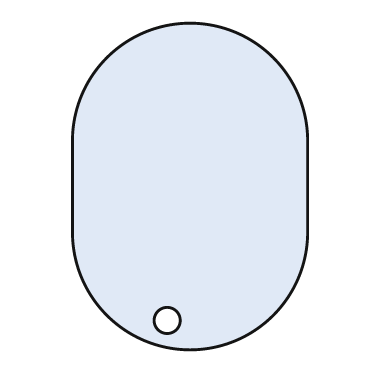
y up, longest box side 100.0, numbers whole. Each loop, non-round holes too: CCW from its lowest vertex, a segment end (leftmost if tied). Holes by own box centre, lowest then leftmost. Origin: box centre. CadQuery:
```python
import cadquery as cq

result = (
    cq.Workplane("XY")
    .moveTo(-36.0, -14.0)
    .threePointArc((0.0, -50.0), (36.0, -14.0))
    .lineTo(36.0, 14.0)
    .threePointArc((0.0, 50.0), (-36.0, 14.0))
    .close()
    .moveTo(-7.0, -41.0)
    .circle(4.0)
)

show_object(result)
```